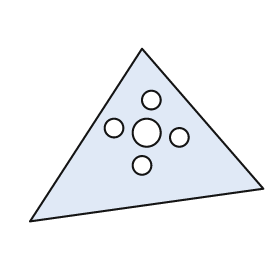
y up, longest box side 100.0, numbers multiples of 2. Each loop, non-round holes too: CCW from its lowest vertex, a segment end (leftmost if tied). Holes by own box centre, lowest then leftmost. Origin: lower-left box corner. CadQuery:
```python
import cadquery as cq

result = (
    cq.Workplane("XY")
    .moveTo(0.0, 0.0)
    .lineTo(100.0, 14.0)
    .lineTo(48.0, 74.0)
    .close()
    .moveTo(48.0, 24.0)
    .circle(4.0)
    .moveTo(64.0, 36.0)
    .circle(4.0)
    .moveTo(50.0, 38.0)
    .circle(6.0)
    .moveTo(36.0, 40.0)
    .circle(4.0)
    .moveTo(52.0, 52.0)
    .circle(4.0)
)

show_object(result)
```